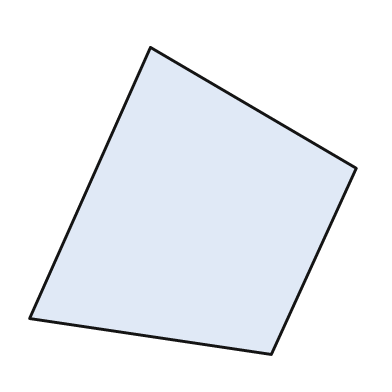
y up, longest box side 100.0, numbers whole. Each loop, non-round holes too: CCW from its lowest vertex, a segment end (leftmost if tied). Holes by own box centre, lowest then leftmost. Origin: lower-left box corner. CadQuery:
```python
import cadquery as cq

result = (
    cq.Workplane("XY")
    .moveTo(74.0, 0.0)
    .lineTo(100.0, 57.0)
    .lineTo(37.0, 94.0)
    .lineTo(0.0, 11.0)
    .close()
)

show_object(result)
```